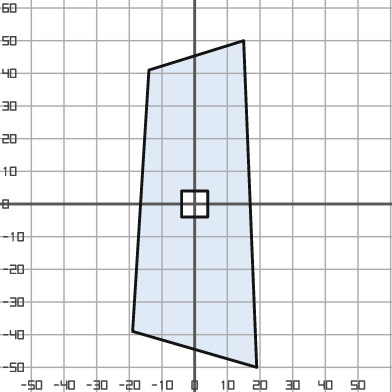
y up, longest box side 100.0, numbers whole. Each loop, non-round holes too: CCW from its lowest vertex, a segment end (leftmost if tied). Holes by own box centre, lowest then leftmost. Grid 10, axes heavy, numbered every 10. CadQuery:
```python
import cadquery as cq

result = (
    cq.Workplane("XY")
    .moveTo(19.0, -50.0)
    .lineTo(15.0, 50.0)
    .lineTo(-14.0, 41.0)
    .lineTo(-19.0, -39.0)
    .close()
    .moveTo(-4.0, -4.0)
    .lineTo(4.0, -4.0)
    .lineTo(4.0, 4.0)
    .lineTo(-4.0, 4.0)
    .close()
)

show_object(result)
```